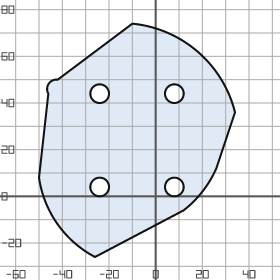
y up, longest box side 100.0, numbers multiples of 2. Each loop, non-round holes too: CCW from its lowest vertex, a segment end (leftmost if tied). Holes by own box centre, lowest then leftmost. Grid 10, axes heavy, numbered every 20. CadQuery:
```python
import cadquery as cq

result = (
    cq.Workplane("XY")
    .moveTo(-26.0, -26.0)
    .lineTo(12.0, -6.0)
    .threePointArc((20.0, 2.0), (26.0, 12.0))
    .lineTo(34.0, 36.0)
    .threePointArc((18.0, 62.0), (-10.0, 74.0))
    .lineTo(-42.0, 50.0)
    .threePointArc((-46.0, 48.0), (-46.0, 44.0))
    .lineTo(-50.0, 8.0)
    .threePointArc((-42.0, -12.0), (-26.0, -26.0))
    .close()
    .moveTo(-24.0, 4.0)
    .circle(4.0)
    .moveTo(8.0, 4.0)
    .circle(4.0)
    .moveTo(-24.0, 44.0)
    .circle(4.0)
    .moveTo(8.0, 44.0)
    .circle(4.0)
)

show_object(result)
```